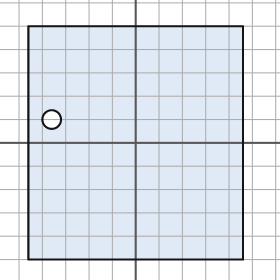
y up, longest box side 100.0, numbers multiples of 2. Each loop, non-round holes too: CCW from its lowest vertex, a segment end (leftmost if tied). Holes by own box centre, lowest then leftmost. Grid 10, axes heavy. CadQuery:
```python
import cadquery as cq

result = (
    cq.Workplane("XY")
    .moveTo(-46.0, -50.0)
    .lineTo(46.0, -50.0)
    .lineTo(46.0, 50.0)
    .lineTo(-46.0, 50.0)
    .close()
    .moveTo(-36.0, 10.0)
    .circle(4.0)
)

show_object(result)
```